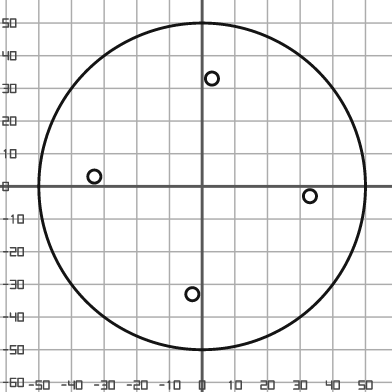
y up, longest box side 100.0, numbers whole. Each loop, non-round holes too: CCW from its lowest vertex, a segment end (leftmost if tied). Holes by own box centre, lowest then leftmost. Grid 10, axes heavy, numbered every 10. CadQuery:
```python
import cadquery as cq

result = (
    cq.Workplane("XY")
    .moveTo(0.0, 0.0)
    .circle(50.0)
    .moveTo(-3.0, -33.0)
    .circle(2.0)
    .moveTo(33.0, -3.0)
    .circle(2.0)
    .moveTo(-33.0, 3.0)
    .circle(2.0)
    .moveTo(3.0, 33.0)
    .circle(2.0)
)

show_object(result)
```